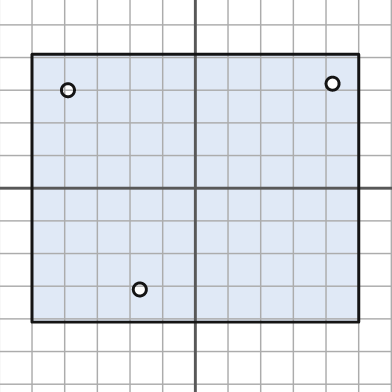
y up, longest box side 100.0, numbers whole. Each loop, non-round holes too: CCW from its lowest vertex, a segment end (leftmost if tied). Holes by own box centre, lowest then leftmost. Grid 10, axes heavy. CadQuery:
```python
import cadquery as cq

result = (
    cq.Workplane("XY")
    .moveTo(-50.0, -41.0)
    .lineTo(50.0, -41.0)
    .lineTo(50.0, 41.0)
    .lineTo(-50.0, 41.0)
    .close()
    .moveTo(-17.0, -31.0)
    .circle(2.0)
    .moveTo(-39.0, 30.0)
    .circle(2.0)
    .moveTo(42.0, 32.0)
    .circle(2.0)
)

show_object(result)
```